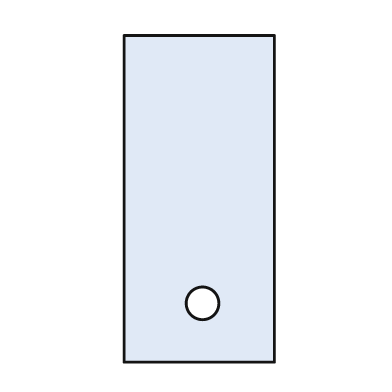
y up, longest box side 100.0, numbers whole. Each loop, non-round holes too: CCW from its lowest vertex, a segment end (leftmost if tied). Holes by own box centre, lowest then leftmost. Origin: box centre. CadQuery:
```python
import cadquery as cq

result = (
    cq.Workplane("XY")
    .moveTo(-23.0, -50.0)
    .lineTo(23.0, -50.0)
    .lineTo(23.0, 50.0)
    .lineTo(-23.0, 50.0)
    .close()
    .moveTo(1.0, -32.0)
    .circle(5.0)
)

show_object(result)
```